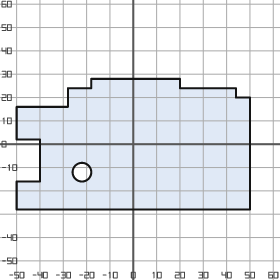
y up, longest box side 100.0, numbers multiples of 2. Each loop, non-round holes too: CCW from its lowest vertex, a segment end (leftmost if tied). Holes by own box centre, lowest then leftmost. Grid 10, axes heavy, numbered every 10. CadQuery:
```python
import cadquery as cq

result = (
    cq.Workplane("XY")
    .moveTo(-50.0, -28.0)
    .lineTo(50.0, -28.0)
    .lineTo(50.0, 20.0)
    .lineTo(44.0, 20.0)
    .lineTo(44.0, 24.0)
    .lineTo(20.0, 24.0)
    .lineTo(20.0, 28.0)
    .lineTo(-18.0, 28.0)
    .lineTo(-18.0, 24.0)
    .lineTo(-28.0, 24.0)
    .lineTo(-28.0, 16.0)
    .lineTo(-50.0, 16.0)
    .lineTo(-50.0, 2.0)
    .lineTo(-40.0, 2.0)
    .lineTo(-40.0, -16.0)
    .lineTo(-50.0, -16.0)
    .close()
    .moveTo(-22.0, -12.0)
    .circle(4.0)
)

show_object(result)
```